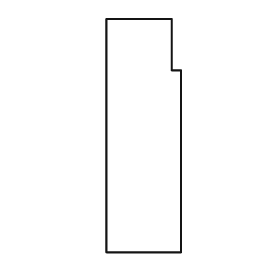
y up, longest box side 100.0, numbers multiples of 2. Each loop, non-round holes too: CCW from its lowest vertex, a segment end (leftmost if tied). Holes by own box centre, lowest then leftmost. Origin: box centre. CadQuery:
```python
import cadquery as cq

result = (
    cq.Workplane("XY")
    .moveTo(-16.0, -50.0)
    .lineTo(16.0, -50.0)
    .lineTo(16.0, 28.0)
    .lineTo(12.0, 28.0)
    .lineTo(12.0, 50.0)
    .lineTo(-16.0, 50.0)
    .close()
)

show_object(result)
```